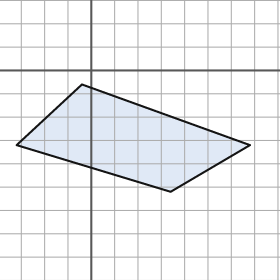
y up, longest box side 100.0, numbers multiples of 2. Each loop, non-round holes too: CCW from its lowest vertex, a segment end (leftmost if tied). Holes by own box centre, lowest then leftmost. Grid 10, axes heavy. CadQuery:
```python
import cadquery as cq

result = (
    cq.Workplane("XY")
    .moveTo(34.0, -52.0)
    .lineTo(68.0, -32.0)
    .lineTo(-4.0, -6.0)
    .lineTo(-32.0, -32.0)
    .close()
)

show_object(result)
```